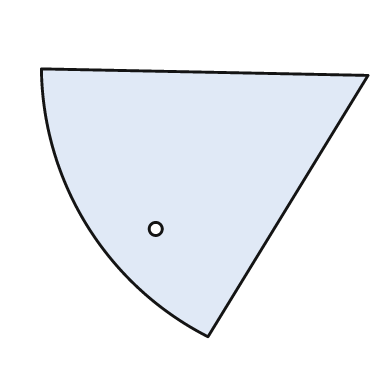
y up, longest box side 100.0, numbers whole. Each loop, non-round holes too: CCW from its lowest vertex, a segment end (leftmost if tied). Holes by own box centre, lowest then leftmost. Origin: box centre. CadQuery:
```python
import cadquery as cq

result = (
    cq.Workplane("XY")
    .moveTo(1.0, -41.0)
    .lineTo(50.0, 39.0)
    .lineTo(-50.0, 41.0)
    .threePointArc((-36.0, -7.0), (1.0, -41.0))
    .close()
    .moveTo(-15.0, -8.0)
    .circle(2.0)
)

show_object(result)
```